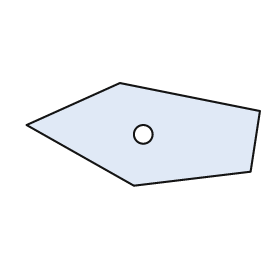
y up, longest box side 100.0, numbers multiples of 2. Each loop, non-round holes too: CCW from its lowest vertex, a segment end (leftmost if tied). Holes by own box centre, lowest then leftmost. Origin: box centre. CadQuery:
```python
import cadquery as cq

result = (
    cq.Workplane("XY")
    .moveTo(-4.0, -22.0)
    .lineTo(46.0, -16.0)
    .lineTo(50.0, 10.0)
    .lineTo(-10.0, 22.0)
    .lineTo(-50.0, 4.0)
    .close()
    .moveTo(0.0, 0.0)
    .circle(4.0)
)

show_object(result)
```